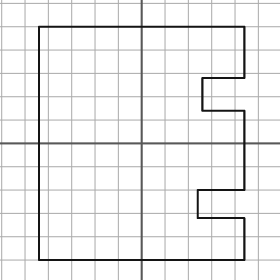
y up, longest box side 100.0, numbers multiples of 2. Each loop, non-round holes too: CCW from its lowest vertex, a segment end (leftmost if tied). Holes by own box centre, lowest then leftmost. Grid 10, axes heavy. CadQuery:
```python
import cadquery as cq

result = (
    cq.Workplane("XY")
    .moveTo(-44.0, -50.0)
    .lineTo(44.0, -50.0)
    .lineTo(44.0, -32.0)
    .lineTo(24.0, -32.0)
    .lineTo(24.0, -20.0)
    .lineTo(44.0, -20.0)
    .lineTo(44.0, 14.0)
    .lineTo(26.0, 14.0)
    .lineTo(26.0, 28.0)
    .lineTo(44.0, 28.0)
    .lineTo(44.0, 50.0)
    .lineTo(-44.0, 50.0)
    .close()
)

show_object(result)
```